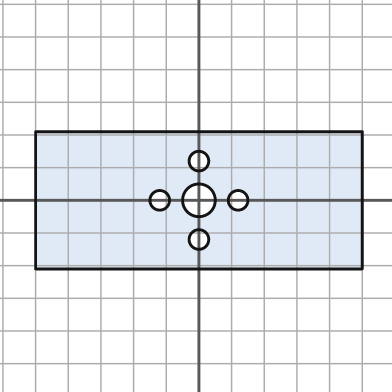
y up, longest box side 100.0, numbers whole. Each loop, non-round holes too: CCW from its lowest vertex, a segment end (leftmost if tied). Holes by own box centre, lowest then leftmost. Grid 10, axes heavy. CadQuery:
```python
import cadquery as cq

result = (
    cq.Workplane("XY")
    .moveTo(-50.0, -21.0)
    .lineTo(50.0, -21.0)
    .lineTo(50.0, 21.0)
    .lineTo(-50.0, 21.0)
    .close()
    .moveTo(0.0, -12.0)
    .circle(3.0)
    .moveTo(-12.0, 0.0)
    .circle(3.0)
    .moveTo(0.0, 0.0)
    .circle(5.0)
    .moveTo(12.0, 0.0)
    .circle(3.0)
    .moveTo(0.0, 12.0)
    .circle(3.0)
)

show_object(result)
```